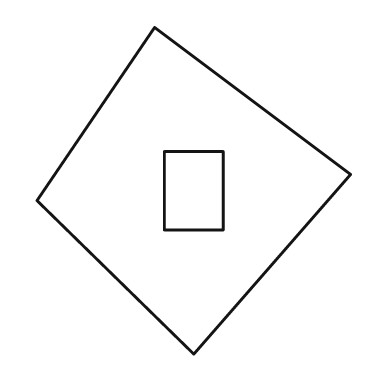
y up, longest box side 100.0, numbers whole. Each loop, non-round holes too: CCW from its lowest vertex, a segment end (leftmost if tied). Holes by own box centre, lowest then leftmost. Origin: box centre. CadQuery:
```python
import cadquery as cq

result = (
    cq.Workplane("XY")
    .moveTo(0.0, -50.0)
    .lineTo(48.0, 5.0)
    .lineTo(-12.0, 50.0)
    .lineTo(-48.0, -3.0)
    .close()
    .moveTo(-9.0, -12.0)
    .lineTo(9.0, -12.0)
    .lineTo(9.0, 12.0)
    .lineTo(-9.0, 12.0)
    .close()
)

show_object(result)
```